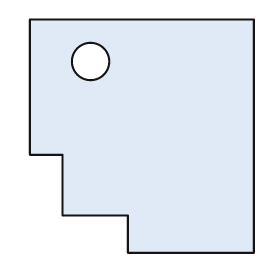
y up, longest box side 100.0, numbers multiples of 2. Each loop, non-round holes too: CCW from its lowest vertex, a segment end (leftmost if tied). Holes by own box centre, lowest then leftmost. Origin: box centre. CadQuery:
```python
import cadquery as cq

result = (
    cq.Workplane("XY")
    .moveTo(-6.0, -50.0)
    .lineTo(48.0, -50.0)
    .lineTo(48.0, 50.0)
    .lineTo(-48.0, 50.0)
    .lineTo(-48.0, -8.0)
    .lineTo(-34.0, -8.0)
    .lineTo(-34.0, -34.0)
    .lineTo(-6.0, -34.0)
    .close()
    .moveTo(-22.0, 32.0)
    .circle(8.0)
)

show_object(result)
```